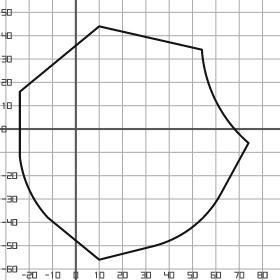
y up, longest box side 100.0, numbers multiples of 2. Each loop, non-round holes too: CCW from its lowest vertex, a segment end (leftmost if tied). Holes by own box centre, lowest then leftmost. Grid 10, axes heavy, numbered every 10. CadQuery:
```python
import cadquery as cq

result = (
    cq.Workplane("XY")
    .moveTo(10.0, -56.0)
    .lineTo(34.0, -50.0)
    .threePointArc((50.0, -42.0), (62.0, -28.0))
    .lineTo(74.0, -6.0)
    .threePointArc((60.0, 12.0), (54.0, 34.0))
    .lineTo(10.0, 44.0)
    .lineTo(-24.0, 16.0)
    .lineTo(-24.0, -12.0)
    .threePointArc((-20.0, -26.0), (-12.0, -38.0))
    .close()
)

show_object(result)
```